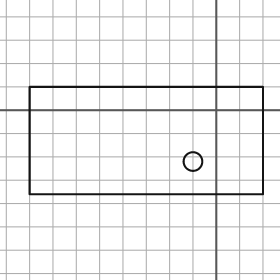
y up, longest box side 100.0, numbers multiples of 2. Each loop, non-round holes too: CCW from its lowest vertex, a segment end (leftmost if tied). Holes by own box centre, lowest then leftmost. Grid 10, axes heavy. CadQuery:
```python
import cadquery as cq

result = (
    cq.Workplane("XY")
    .moveTo(-80.0, -36.0)
    .lineTo(20.0, -36.0)
    .lineTo(20.0, 10.0)
    .lineTo(-80.0, 10.0)
    .close()
    .moveTo(-10.0, -22.0)
    .circle(4.0)
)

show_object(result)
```